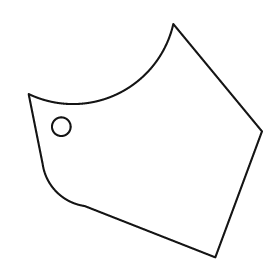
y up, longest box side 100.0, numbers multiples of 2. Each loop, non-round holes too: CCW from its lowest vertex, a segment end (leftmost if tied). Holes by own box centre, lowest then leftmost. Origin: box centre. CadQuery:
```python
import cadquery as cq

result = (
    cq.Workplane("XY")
    .moveTo(30.0, -50.0)
    .lineTo(50.0, 4.0)
    .lineTo(12.0, 50.0)
    .threePointArc((-12.0, 20.0), (-50.0, 20.0))
    .lineTo(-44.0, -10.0)
    .threePointArc((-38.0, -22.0), (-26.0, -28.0))
    .close()
    .moveTo(-36.0, 6.0)
    .circle(4.0)
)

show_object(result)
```